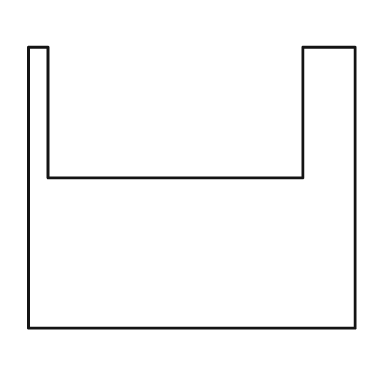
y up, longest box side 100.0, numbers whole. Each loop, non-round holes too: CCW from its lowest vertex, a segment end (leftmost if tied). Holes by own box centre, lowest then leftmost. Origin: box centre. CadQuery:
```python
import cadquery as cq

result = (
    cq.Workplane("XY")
    .moveTo(-50.0, -43.0)
    .lineTo(50.0, -43.0)
    .lineTo(50.0, 43.0)
    .lineTo(34.0, 43.0)
    .lineTo(34.0, 3.0)
    .lineTo(-44.0, 3.0)
    .lineTo(-44.0, 43.0)
    .lineTo(-50.0, 43.0)
    .close()
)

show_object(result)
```